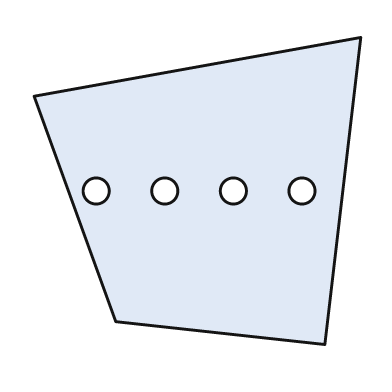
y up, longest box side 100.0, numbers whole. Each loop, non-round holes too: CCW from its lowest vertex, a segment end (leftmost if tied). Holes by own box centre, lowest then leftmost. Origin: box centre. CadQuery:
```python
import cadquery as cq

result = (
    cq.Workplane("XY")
    .moveTo(39.0, -47.0)
    .lineTo(50.0, 47.0)
    .lineTo(-50.0, 29.0)
    .lineTo(-25.0, -40.0)
    .close()
    .moveTo(-31.0, 0.0)
    .circle(4.0)
    .moveTo(-10.0, 0.0)
    .circle(4.0)
    .moveTo(11.0, 0.0)
    .circle(4.0)
    .moveTo(32.0, 0.0)
    .circle(4.0)
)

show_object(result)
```